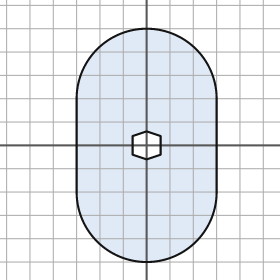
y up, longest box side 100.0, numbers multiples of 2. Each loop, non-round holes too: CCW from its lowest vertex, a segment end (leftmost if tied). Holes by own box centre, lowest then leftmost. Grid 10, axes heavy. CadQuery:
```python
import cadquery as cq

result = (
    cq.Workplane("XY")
    .moveTo(-30.0, -20.0)
    .threePointArc((0.0, -50.0), (30.0, -20.0))
    .lineTo(30.0, 20.0)
    .threePointArc((0.0, 50.0), (-30.0, 20.0))
    .close()
    .moveTo(0.0, -6.0)
    .lineTo(6.0, -4.0)
    .lineTo(6.0, 4.0)
    .lineTo(0.0, 6.0)
    .lineTo(-6.0, 4.0)
    .lineTo(-6.0, -4.0)
    .close()
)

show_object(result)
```